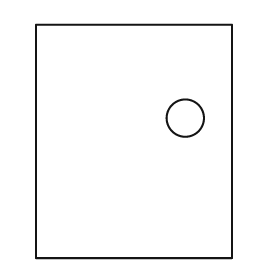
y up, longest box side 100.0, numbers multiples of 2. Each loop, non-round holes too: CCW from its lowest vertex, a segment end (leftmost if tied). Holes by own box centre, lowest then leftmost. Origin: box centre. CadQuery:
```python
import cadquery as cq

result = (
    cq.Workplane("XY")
    .moveTo(-42.0, -50.0)
    .lineTo(42.0, -50.0)
    .lineTo(42.0, 50.0)
    .lineTo(-42.0, 50.0)
    .close()
    .moveTo(22.0, 10.0)
    .circle(8.0)
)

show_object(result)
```